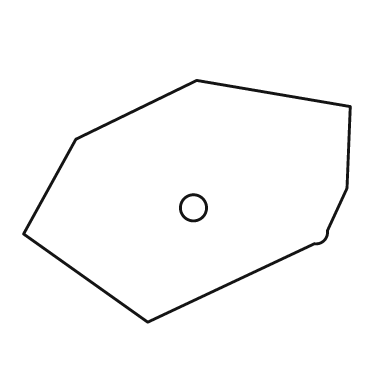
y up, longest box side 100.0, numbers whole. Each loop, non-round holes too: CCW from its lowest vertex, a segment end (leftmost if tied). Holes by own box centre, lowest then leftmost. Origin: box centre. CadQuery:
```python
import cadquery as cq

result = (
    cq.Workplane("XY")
    .moveTo(-12.0, -37.0)
    .lineTo(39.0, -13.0)
    .threePointArc((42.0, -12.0), (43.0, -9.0))
    .lineTo(49.0, 4.0)
    .lineTo(50.0, 29.0)
    .lineTo(3.0, 37.0)
    .lineTo(-34.0, 19.0)
    .lineTo(-50.0, -10.0)
    .close()
    .moveTo(2.0, -2.0)
    .circle(4.0)
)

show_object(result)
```